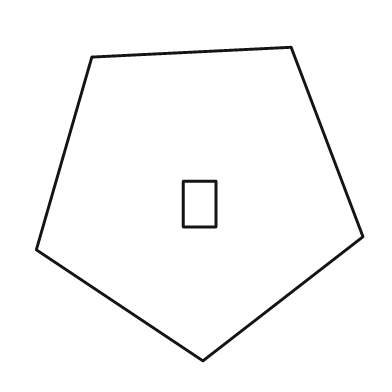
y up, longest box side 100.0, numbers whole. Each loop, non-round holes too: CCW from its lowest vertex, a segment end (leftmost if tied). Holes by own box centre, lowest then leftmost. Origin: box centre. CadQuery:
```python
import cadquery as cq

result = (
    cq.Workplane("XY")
    .moveTo(1.0, -48.0)
    .lineTo(50.0, -10.0)
    .lineTo(28.0, 48.0)
    .lineTo(-33.0, 45.0)
    .lineTo(-50.0, -14.0)
    .close()
    .moveTo(-5.0, -7.0)
    .lineTo(5.0, -7.0)
    .lineTo(5.0, 7.0)
    .lineTo(-5.0, 7.0)
    .close()
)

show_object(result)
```